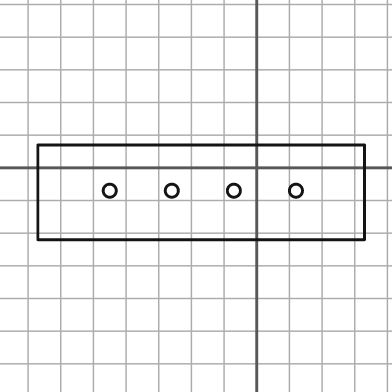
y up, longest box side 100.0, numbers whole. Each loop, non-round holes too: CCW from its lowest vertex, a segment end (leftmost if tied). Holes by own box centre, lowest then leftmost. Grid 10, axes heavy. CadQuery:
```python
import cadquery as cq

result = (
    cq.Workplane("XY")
    .moveTo(-67.0, -22.0)
    .lineTo(33.0, -22.0)
    .lineTo(33.0, 7.0)
    .lineTo(-67.0, 7.0)
    .close()
    .moveTo(-45.0, -7.0)
    .circle(2.0)
    .moveTo(-26.0, -7.0)
    .circle(2.0)
    .moveTo(-7.0, -7.0)
    .circle(2.0)
    .moveTo(12.0, -7.0)
    .circle(2.0)
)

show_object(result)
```